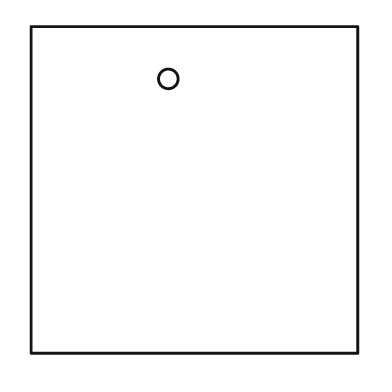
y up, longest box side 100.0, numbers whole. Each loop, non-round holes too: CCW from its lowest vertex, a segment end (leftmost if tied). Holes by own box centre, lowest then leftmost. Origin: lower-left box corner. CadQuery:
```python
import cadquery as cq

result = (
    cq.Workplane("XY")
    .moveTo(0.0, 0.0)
    .lineTo(100.0, 0.0)
    .lineTo(100.0, 100.0)
    .lineTo(0.0, 100.0)
    .close()
    .moveTo(42.0, 84.0)
    .circle(3.0)
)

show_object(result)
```